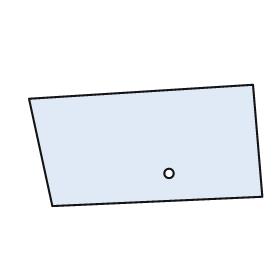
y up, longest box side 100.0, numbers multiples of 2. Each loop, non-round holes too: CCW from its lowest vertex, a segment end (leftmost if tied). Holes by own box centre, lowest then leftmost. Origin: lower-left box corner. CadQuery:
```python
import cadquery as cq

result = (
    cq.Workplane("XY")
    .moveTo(10.0, 0.0)
    .lineTo(100.0, 4.0)
    .lineTo(96.0, 52.0)
    .lineTo(0.0, 46.0)
    .close()
    .moveTo(60.0, 14.0)
    .circle(2.0)
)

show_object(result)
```